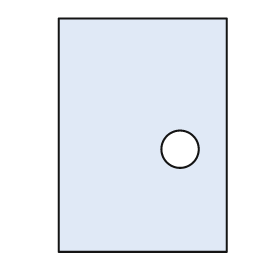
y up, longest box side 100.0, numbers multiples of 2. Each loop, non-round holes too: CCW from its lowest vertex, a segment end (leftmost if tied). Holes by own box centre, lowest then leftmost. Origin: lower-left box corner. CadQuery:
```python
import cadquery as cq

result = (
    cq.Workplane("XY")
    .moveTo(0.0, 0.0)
    .lineTo(72.0, 0.0)
    .lineTo(72.0, 100.0)
    .lineTo(0.0, 100.0)
    .close()
    .moveTo(52.0, 44.0)
    .circle(8.0)
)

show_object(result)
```